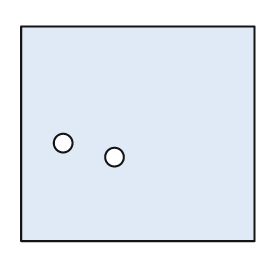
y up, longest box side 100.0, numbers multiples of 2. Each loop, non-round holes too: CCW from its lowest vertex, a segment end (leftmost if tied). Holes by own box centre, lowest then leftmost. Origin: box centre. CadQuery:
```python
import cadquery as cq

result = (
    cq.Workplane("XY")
    .moveTo(-50.0, -46.0)
    .lineTo(50.0, -46.0)
    .lineTo(50.0, 46.0)
    .lineTo(-50.0, 46.0)
    .close()
    .moveTo(-10.0, -10.0)
    .circle(4.0)
    .moveTo(-32.0, -4.0)
    .circle(4.0)
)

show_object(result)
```